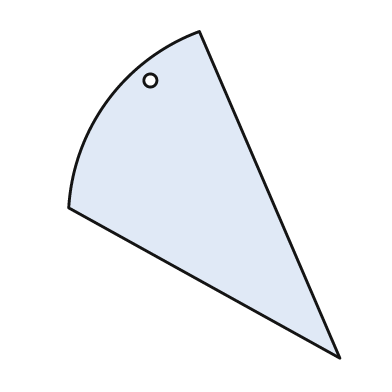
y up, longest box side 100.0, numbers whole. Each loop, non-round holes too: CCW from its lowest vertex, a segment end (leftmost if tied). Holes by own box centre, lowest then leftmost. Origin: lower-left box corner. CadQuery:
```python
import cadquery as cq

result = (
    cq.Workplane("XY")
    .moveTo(83.0, 0.0)
    .lineTo(40.0, 100.0)
    .threePointArc((12.0, 79.0), (0.0, 46.0))
    .close()
    .moveTo(25.0, 85.0)
    .circle(2.0)
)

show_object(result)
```